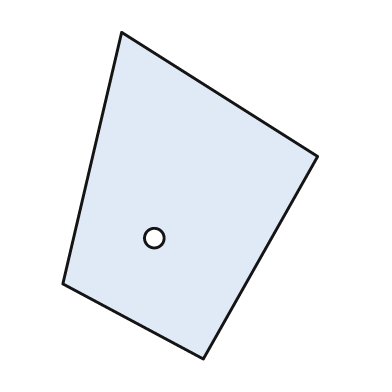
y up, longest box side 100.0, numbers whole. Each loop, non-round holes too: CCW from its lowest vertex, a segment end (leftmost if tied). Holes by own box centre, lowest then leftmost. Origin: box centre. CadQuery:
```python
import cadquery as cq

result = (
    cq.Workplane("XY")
    .moveTo(4.0, -50.0)
    .lineTo(39.0, 12.0)
    .lineTo(-21.0, 50.0)
    .lineTo(-39.0, -27.0)
    .close()
    .moveTo(-11.0, -13.0)
    .circle(3.0)
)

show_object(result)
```